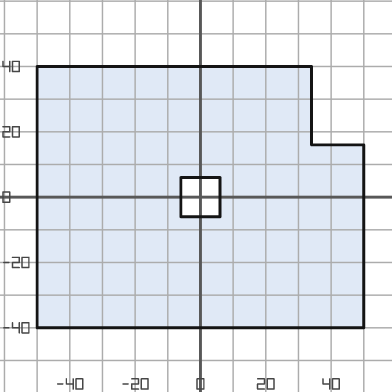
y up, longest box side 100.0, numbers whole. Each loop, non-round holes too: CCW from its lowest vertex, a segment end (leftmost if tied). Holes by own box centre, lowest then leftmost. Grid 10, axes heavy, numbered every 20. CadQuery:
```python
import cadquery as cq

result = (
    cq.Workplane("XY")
    .moveTo(-50.0, -40.0)
    .lineTo(50.0, -40.0)
    .lineTo(50.0, 16.0)
    .lineTo(34.0, 16.0)
    .lineTo(34.0, 40.0)
    .lineTo(-50.0, 40.0)
    .close()
    .moveTo(-6.0, -6.0)
    .lineTo(6.0, -6.0)
    .lineTo(6.0, 6.0)
    .lineTo(-6.0, 6.0)
    .close()
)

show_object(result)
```